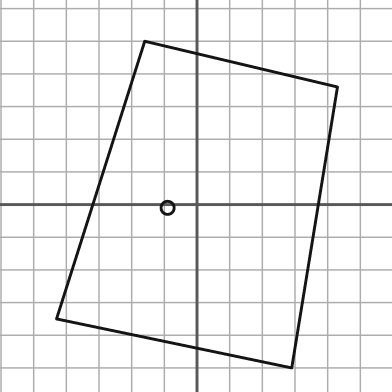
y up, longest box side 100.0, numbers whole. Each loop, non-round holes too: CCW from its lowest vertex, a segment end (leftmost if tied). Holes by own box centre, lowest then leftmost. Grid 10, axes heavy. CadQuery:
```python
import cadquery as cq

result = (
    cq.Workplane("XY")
    .moveTo(29.0, -50.0)
    .lineTo(43.0, 36.0)
    .lineTo(-16.0, 50.0)
    .lineTo(-43.0, -35.0)
    .close()
    .moveTo(-9.0, -1.0)
    .circle(2.0)
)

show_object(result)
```